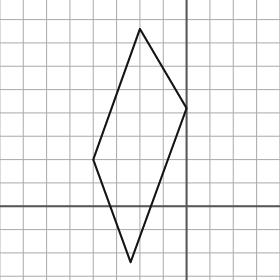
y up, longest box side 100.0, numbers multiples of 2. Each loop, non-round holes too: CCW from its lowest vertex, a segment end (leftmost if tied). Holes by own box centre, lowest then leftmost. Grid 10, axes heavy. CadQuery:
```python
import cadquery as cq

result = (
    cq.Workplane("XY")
    .moveTo(-24.0, -24.0)
    .lineTo(0.0, 42.0)
    .lineTo(-20.0, 76.0)
    .lineTo(-40.0, 20.0)
    .close()
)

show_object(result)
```